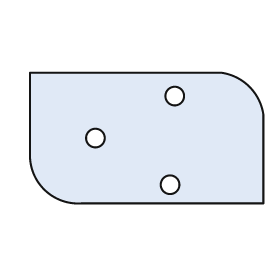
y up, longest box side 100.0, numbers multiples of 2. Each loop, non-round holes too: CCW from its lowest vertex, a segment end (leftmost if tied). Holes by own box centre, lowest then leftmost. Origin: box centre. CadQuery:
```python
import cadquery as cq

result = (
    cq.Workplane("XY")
    .moveTo(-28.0, -28.0)
    .lineTo(50.0, -28.0)
    .lineTo(50.0, 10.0)
    .threePointArc((44.0, 22.0), (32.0, 28.0))
    .lineTo(-50.0, 28.0)
    .lineTo(-50.0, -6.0)
    .threePointArc((-44.0, -22.0), (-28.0, -28.0))
    .close()
    .moveTo(10.0, -20.0)
    .circle(4.0)
    .moveTo(-22.0, 0.0)
    .circle(4.0)
    .moveTo(12.0, 18.0)
    .circle(4.0)
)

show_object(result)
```